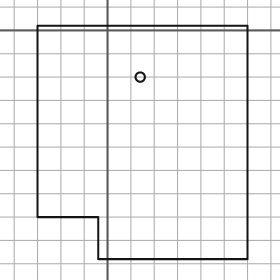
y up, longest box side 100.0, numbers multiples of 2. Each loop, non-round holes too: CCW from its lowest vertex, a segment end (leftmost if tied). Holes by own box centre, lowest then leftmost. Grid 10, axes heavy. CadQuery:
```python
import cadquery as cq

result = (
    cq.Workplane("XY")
    .moveTo(-4.0, -98.0)
    .lineTo(60.0, -98.0)
    .lineTo(60.0, 2.0)
    .lineTo(-30.0, 2.0)
    .lineTo(-30.0, -80.0)
    .lineTo(-4.0, -80.0)
    .close()
    .moveTo(14.0, -20.0)
    .circle(2.0)
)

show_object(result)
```